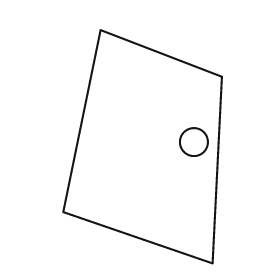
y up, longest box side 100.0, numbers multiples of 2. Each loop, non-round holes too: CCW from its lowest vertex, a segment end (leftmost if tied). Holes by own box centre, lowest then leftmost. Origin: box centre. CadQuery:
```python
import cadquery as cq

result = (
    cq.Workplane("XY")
    .moveTo(30.0, -50.0)
    .lineTo(34.0, 30.0)
    .lineTo(-18.0, 50.0)
    .lineTo(-34.0, -28.0)
    .close()
    .moveTo(22.0, 2.0)
    .circle(6.0)
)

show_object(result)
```